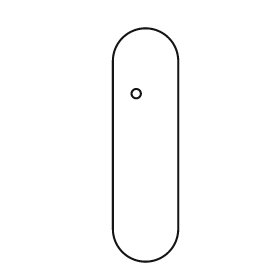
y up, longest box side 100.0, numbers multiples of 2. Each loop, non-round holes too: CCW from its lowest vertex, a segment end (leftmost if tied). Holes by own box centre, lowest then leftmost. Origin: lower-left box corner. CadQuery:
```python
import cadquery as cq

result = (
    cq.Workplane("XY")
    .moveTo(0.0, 14.0)
    .threePointArc((14.0, 0.0), (28.0, 14.0))
    .lineTo(28.0, 86.0)
    .threePointArc((14.0, 100.0), (0.0, 86.0))
    .close()
    .moveTo(10.0, 72.0)
    .circle(2.0)
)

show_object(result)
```